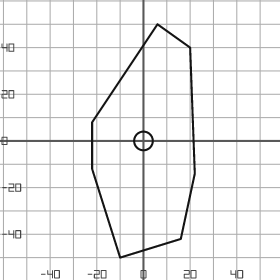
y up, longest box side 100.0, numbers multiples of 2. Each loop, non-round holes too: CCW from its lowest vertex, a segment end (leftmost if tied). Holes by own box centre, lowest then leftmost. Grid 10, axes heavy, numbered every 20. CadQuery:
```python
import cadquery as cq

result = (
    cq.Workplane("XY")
    .moveTo(-10.0, -50.0)
    .lineTo(16.0, -42.0)
    .lineTo(22.0, -14.0)
    .lineTo(20.0, 40.0)
    .lineTo(6.0, 50.0)
    .lineTo(-22.0, 8.0)
    .lineTo(-22.0, -12.0)
    .close()
    .moveTo(0.0, 0.0)
    .circle(4.0)
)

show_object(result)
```